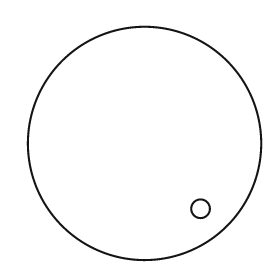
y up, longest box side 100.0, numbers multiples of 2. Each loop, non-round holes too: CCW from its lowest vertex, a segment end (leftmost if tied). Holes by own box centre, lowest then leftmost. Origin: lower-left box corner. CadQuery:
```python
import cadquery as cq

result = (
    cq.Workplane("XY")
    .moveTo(50.0, 50.0)
    .circle(50.0)
    .moveTo(74.0, 22.0)
    .circle(4.0)
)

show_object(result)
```